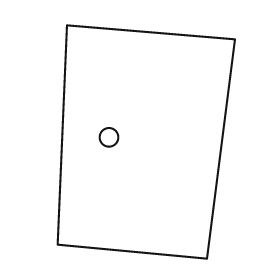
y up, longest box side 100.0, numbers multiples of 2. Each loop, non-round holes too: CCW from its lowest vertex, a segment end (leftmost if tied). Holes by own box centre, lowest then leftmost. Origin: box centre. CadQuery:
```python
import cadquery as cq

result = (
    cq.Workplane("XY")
    .moveTo(26.0, -50.0)
    .lineTo(38.0, 44.0)
    .lineTo(-34.0, 50.0)
    .lineTo(-38.0, -44.0)
    .close()
    .moveTo(-16.0, 2.0)
    .circle(4.0)
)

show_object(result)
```